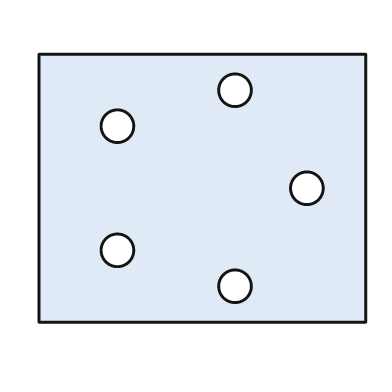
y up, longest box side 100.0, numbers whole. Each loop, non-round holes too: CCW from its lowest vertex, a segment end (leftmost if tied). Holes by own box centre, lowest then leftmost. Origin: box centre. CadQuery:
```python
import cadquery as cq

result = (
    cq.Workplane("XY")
    .moveTo(-50.0, -41.0)
    .lineTo(50.0, -41.0)
    .lineTo(50.0, 41.0)
    .lineTo(-50.0, 41.0)
    .close()
    .moveTo(10.0, -30.0)
    .circle(5.0)
    .moveTo(-26.0, -19.0)
    .circle(5.0)
    .moveTo(32.0, 0.0)
    .circle(5.0)
    .moveTo(-26.0, 19.0)
    .circle(5.0)
    .moveTo(10.0, 30.0)
    .circle(5.0)
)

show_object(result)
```